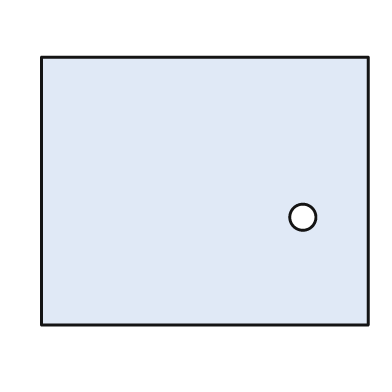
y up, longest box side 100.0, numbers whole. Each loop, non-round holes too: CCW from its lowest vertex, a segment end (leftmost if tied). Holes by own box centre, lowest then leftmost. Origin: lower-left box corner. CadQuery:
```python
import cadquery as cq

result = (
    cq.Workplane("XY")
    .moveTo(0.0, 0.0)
    .lineTo(100.0, 0.0)
    .lineTo(100.0, 82.0)
    .lineTo(0.0, 82.0)
    .close()
    .moveTo(80.0, 33.0)
    .circle(4.0)
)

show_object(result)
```